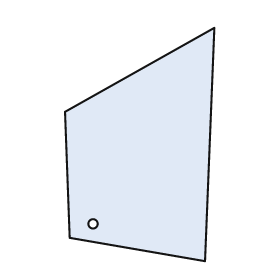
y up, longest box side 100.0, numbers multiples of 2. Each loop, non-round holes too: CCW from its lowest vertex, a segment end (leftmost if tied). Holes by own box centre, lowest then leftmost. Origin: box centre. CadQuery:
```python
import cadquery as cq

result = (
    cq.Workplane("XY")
    .moveTo(28.0, -50.0)
    .lineTo(32.0, 50.0)
    .lineTo(-32.0, 14.0)
    .lineTo(-30.0, -40.0)
    .close()
    .moveTo(-20.0, -34.0)
    .circle(2.0)
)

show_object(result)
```